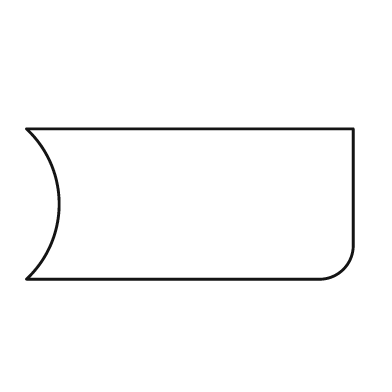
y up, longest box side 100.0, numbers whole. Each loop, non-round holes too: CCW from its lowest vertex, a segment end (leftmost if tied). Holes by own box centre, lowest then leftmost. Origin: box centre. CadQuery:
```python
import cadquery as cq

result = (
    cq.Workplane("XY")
    .moveTo(-50.0, -23.0)
    .lineTo(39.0, -23.0)
    .threePointArc((47.0, -20.0), (50.0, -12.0))
    .lineTo(50.0, 23.0)
    .lineTo(-50.0, 23.0)
    .threePointArc((-40.0, 0.0), (-50.0, -23.0))
    .close()
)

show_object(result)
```